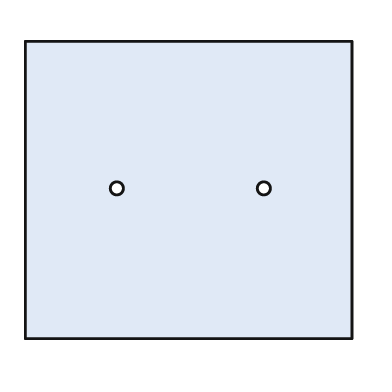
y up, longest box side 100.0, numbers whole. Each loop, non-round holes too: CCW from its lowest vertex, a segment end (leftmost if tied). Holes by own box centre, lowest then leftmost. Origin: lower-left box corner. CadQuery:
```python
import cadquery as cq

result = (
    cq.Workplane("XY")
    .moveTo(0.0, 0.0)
    .lineTo(100.0, 0.0)
    .lineTo(100.0, 91.0)
    .lineTo(0.0, 91.0)
    .close()
    .moveTo(28.0, 46.0)
    .circle(2.0)
    .moveTo(73.0, 46.0)
    .circle(2.0)
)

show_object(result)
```